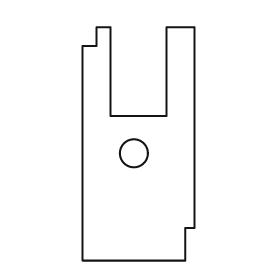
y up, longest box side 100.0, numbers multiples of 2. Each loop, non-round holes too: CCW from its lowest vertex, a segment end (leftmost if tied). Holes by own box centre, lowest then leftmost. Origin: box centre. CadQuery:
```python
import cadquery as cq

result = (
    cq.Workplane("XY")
    .moveTo(-24.0, -50.0)
    .lineTo(20.0, -50.0)
    .lineTo(20.0, -36.0)
    .lineTo(24.0, -36.0)
    .lineTo(24.0, 50.0)
    .lineTo(12.0, 50.0)
    .lineTo(12.0, 12.0)
    .lineTo(-12.0, 12.0)
    .lineTo(-12.0, 50.0)
    .lineTo(-18.0, 50.0)
    .lineTo(-18.0, 42.0)
    .lineTo(-24.0, 42.0)
    .close()
    .moveTo(-2.0, -4.0)
    .circle(6.0)
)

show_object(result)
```